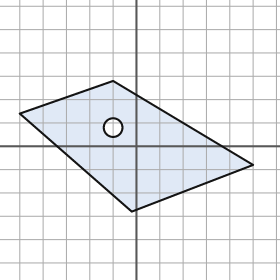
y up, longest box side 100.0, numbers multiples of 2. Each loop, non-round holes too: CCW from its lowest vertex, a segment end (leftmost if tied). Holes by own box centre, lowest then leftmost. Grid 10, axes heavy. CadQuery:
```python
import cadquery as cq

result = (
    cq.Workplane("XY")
    .moveTo(-2.0, -28.0)
    .lineTo(50.0, -8.0)
    .lineTo(-10.0, 28.0)
    .lineTo(-50.0, 14.0)
    .close()
    .moveTo(-10.0, 8.0)
    .circle(4.0)
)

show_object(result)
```